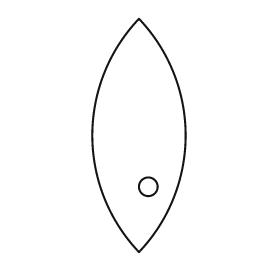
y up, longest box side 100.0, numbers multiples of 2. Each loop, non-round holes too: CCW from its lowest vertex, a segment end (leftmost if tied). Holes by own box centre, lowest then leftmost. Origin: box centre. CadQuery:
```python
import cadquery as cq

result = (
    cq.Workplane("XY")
    .moveTo(0.0, -50.0)
    .threePointArc((20.0, 0.0), (0.0, 50.0))
    .threePointArc((-20.0, 0.0), (0.0, -50.0))
    .close()
    .moveTo(4.0, -22.0)
    .circle(4.0)
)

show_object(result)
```